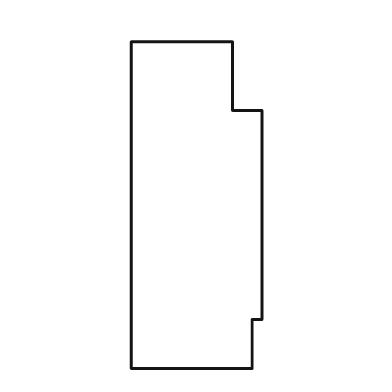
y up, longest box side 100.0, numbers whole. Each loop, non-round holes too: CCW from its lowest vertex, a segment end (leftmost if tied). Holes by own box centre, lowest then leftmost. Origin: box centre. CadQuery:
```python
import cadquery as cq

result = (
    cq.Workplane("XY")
    .moveTo(-20.0, -50.0)
    .lineTo(17.0, -50.0)
    .lineTo(17.0, -35.0)
    .lineTo(20.0, -35.0)
    .lineTo(20.0, 29.0)
    .lineTo(11.0, 29.0)
    .lineTo(11.0, 50.0)
    .lineTo(-20.0, 50.0)
    .close()
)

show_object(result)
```